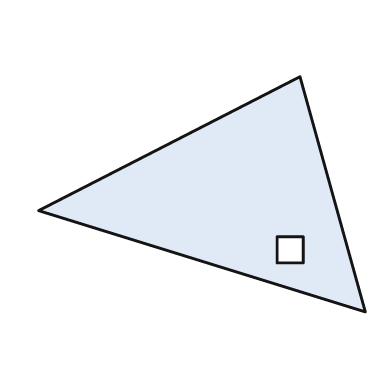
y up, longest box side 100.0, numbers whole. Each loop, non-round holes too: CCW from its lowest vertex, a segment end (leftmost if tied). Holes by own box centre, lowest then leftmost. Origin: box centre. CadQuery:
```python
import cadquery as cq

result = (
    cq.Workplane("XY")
    .moveTo(50.0, -36.0)
    .lineTo(30.0, 36.0)
    .lineTo(-50.0, -5.0)
    .close()
    .moveTo(23.0, -21.0)
    .lineTo(31.0, -21.0)
    .lineTo(31.0, -13.0)
    .lineTo(23.0, -13.0)
    .close()
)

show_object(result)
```